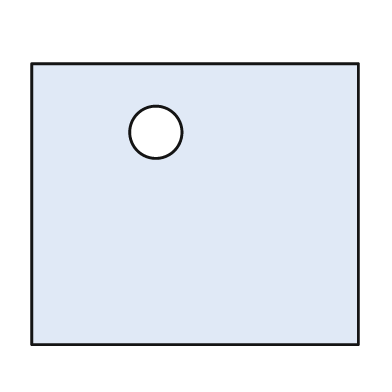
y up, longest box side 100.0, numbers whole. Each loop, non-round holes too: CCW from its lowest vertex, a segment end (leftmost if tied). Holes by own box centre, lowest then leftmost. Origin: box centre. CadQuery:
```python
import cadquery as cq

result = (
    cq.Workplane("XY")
    .moveTo(-50.0, -43.0)
    .lineTo(50.0, -43.0)
    .lineTo(50.0, 43.0)
    .lineTo(-50.0, 43.0)
    .close()
    .moveTo(-12.0, 22.0)
    .circle(8.0)
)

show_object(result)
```